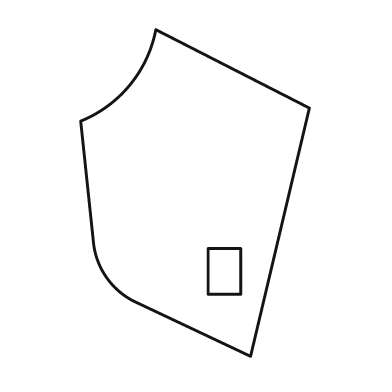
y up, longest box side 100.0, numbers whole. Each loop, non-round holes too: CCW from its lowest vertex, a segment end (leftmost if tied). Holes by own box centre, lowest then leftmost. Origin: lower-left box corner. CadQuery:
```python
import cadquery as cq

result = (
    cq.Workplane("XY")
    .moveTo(52.0, 0.0)
    .lineTo(70.0, 76.0)
    .lineTo(23.0, 100.0)
    .threePointArc((15.0, 83.0), (0.0, 72.0))
    .lineTo(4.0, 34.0)
    .threePointArc((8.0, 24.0), (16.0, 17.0))
    .close()
    .moveTo(39.0, 19.0)
    .lineTo(49.0, 19.0)
    .lineTo(49.0, 33.0)
    .lineTo(39.0, 33.0)
    .close()
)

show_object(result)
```